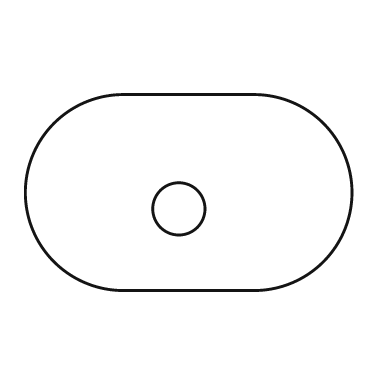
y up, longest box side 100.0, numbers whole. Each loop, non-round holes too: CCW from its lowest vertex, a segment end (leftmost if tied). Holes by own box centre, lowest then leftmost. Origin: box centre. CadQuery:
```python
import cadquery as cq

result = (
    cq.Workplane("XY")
    .moveTo(-20.0, -30.0)
    .lineTo(20.0, -30.0)
    .threePointArc((50.0, 0.0), (20.0, 30.0))
    .lineTo(-20.0, 30.0)
    .threePointArc((-50.0, 0.0), (-20.0, -30.0))
    .close()
    .moveTo(-3.0, -5.0)
    .circle(8.0)
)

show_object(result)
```